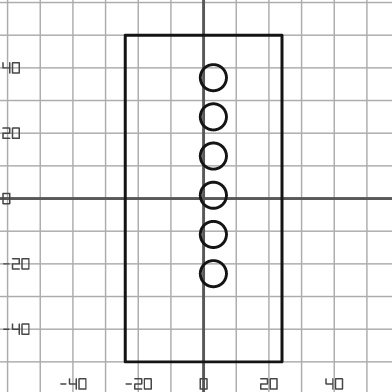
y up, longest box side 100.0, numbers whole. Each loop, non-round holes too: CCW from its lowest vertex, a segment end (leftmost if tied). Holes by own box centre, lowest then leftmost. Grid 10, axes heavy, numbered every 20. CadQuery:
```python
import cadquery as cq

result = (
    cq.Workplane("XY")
    .moveTo(-24.0, -50.0)
    .lineTo(24.0, -50.0)
    .lineTo(24.0, 50.0)
    .lineTo(-24.0, 50.0)
    .close()
    .moveTo(3.0, -23.0)
    .circle(4.0)
    .moveTo(3.0, -11.0)
    .circle(4.0)
    .moveTo(3.0, 1.0)
    .circle(4.0)
    .moveTo(3.0, 13.0)
    .circle(4.0)
    .moveTo(3.0, 25.0)
    .circle(4.0)
    .moveTo(3.0, 37.0)
    .circle(4.0)
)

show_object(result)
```